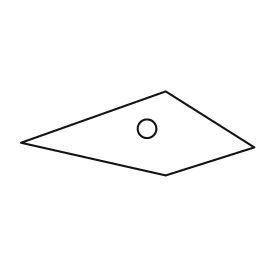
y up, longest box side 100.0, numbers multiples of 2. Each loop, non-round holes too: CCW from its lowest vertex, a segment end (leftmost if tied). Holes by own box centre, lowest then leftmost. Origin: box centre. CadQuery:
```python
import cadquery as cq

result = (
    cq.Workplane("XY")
    .moveTo(12.0, -18.0)
    .lineTo(50.0, -6.0)
    .lineTo(12.0, 18.0)
    .lineTo(-50.0, -4.0)
    .close()
    .moveTo(4.0, 2.0)
    .circle(4.0)
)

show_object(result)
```